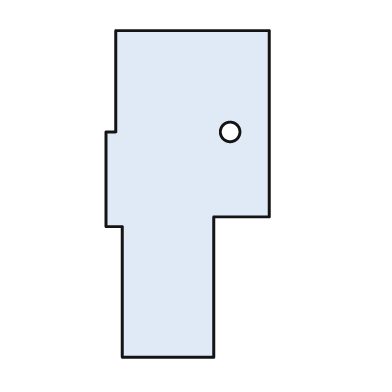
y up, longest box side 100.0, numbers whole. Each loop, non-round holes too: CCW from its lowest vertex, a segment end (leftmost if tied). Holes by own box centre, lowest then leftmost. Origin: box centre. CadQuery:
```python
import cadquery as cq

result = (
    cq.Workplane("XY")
    .moveTo(-20.0, -50.0)
    .lineTo(8.0, -50.0)
    .lineTo(8.0, -7.0)
    .lineTo(25.0, -7.0)
    .lineTo(25.0, 50.0)
    .lineTo(-22.0, 50.0)
    .lineTo(-22.0, 19.0)
    .lineTo(-25.0, 19.0)
    .lineTo(-25.0, -10.0)
    .lineTo(-20.0, -10.0)
    .close()
    .moveTo(13.0, 19.0)
    .circle(3.0)
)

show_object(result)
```